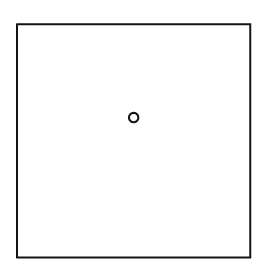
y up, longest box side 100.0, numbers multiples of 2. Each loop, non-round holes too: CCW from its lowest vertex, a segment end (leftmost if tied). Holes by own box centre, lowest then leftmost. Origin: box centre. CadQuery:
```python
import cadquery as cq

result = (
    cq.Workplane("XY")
    .moveTo(-50.0, -50.0)
    .lineTo(50.0, -50.0)
    .lineTo(50.0, 50.0)
    .lineTo(-50.0, 50.0)
    .close()
    .moveTo(0.0, 10.0)
    .circle(2.0)
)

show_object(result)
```